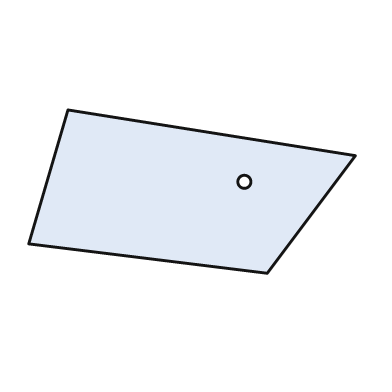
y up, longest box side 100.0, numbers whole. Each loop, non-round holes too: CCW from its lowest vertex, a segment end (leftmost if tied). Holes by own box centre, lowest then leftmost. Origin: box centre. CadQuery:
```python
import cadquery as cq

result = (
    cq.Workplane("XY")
    .moveTo(23.0, -25.0)
    .lineTo(50.0, 11.0)
    .lineTo(-38.0, 25.0)
    .lineTo(-50.0, -16.0)
    .close()
    .moveTo(16.0, 3.0)
    .circle(2.0)
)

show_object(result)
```